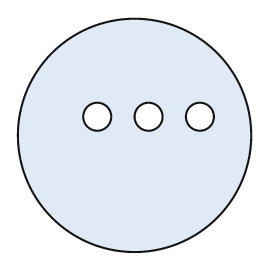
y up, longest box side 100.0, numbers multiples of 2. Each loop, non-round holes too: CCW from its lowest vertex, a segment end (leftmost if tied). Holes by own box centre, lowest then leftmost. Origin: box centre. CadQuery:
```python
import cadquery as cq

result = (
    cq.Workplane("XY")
    .moveTo(0.0, 0.0)
    .circle(50.0)
    .moveTo(-16.0, 8.0)
    .circle(6.0)
    .moveTo(6.0, 8.0)
    .circle(6.0)
    .moveTo(28.0, 8.0)
    .circle(6.0)
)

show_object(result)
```